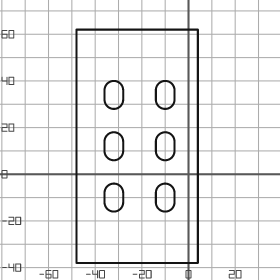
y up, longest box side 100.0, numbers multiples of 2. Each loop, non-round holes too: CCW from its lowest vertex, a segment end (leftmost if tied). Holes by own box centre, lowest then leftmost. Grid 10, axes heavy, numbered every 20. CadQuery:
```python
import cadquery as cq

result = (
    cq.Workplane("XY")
    .moveTo(-48.0, -38.0)
    .lineTo(4.0, -38.0)
    .lineTo(4.0, 62.0)
    .lineTo(-48.0, 62.0)
    .close()
    .moveTo(-36.0, -12.0)
    .threePointArc((-32.0, -16.0), (-28.0, -12.0))
    .lineTo(-28.0, -8.0)
    .threePointArc((-32.0, -4.0), (-36.0, -8.0))
    .close()
    .moveTo(-14.0, -12.0)
    .threePointArc((-10.0, -16.0), (-6.0, -12.0))
    .lineTo(-6.0, -8.0)
    .threePointArc((-10.0, -4.0), (-14.0, -8.0))
    .close()
    .moveTo(-36.0, 10.0)
    .threePointArc((-32.0, 6.0), (-28.0, 10.0))
    .lineTo(-28.0, 14.0)
    .threePointArc((-32.0, 18.0), (-36.0, 14.0))
    .close()
    .moveTo(-14.0, 10.0)
    .threePointArc((-10.0, 6.0), (-6.0, 10.0))
    .lineTo(-6.0, 14.0)
    .threePointArc((-10.0, 18.0), (-14.0, 14.0))
    .close()
    .moveTo(-36.0, 32.0)
    .threePointArc((-32.0, 28.0), (-28.0, 32.0))
    .lineTo(-28.0, 36.0)
    .threePointArc((-32.0, 40.0), (-36.0, 36.0))
    .close()
    .moveTo(-14.0, 32.0)
    .threePointArc((-10.0, 28.0), (-6.0, 32.0))
    .lineTo(-6.0, 36.0)
    .threePointArc((-10.0, 40.0), (-14.0, 36.0))
    .close()
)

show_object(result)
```